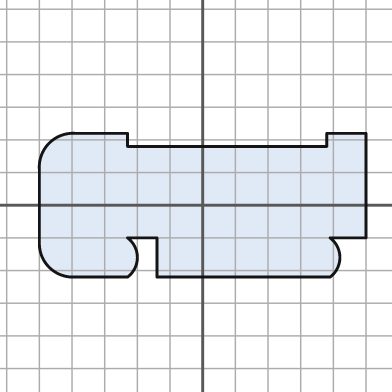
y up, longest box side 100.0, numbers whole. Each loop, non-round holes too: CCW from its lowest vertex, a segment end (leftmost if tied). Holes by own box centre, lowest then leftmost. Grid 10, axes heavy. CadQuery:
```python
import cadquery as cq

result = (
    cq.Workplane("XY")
    .moveTo(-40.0, -22.0)
    .lineTo(-23.0, -22.0)
    .threePointArc((-20.0, -16.0), (-23.0, -10.0))
    .lineTo(-14.0, -10.0)
    .lineTo(-14.0, -22.0)
    .lineTo(39.0, -22.0)
    .threePointArc((42.0, -16.0), (39.0, -10.0))
    .lineTo(50.0, -10.0)
    .lineTo(50.0, 22.0)
    .lineTo(38.0, 22.0)
    .lineTo(38.0, 18.0)
    .lineTo(-23.0, 18.0)
    .lineTo(-23.0, 22.0)
    .lineTo(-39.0, 22.0)
    .threePointArc((-47.0, 19.0), (-50.0, 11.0))
    .lineTo(-50.0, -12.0)
    .threePointArc((-47.0, -19.0), (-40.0, -22.0))
    .close()
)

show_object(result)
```